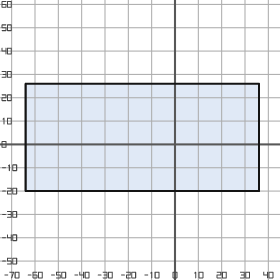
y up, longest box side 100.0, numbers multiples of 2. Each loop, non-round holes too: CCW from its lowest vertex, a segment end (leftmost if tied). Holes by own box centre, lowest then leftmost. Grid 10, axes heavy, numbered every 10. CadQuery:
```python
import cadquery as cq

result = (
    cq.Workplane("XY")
    .moveTo(-64.0, -20.0)
    .lineTo(36.0, -20.0)
    .lineTo(36.0, 26.0)
    .lineTo(-64.0, 26.0)
    .close()
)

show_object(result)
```